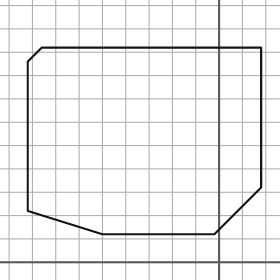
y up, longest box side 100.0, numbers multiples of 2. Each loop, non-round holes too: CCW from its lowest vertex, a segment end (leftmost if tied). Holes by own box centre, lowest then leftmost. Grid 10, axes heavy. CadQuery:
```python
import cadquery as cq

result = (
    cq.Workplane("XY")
    .moveTo(-50.0, 12.0)
    .lineTo(-2.0, 12.0)
    .lineTo(18.0, 32.0)
    .lineTo(18.0, 92.0)
    .lineTo(-76.0, 92.0)
    .lineTo(-82.0, 86.0)
    .lineTo(-82.0, 22.0)
    .close()
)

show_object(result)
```